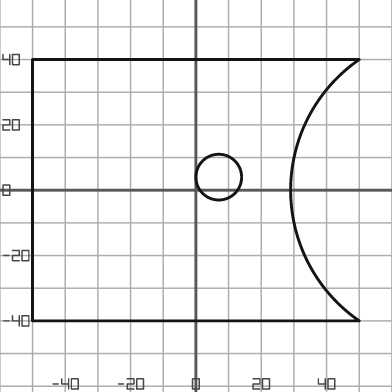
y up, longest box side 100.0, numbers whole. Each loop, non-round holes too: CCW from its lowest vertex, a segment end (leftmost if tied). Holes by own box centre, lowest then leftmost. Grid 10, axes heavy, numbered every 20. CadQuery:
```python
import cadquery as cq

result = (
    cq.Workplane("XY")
    .moveTo(-50.0, -40.0)
    .lineTo(50.0, -40.0)
    .threePointArc((29.0, 0.0), (50.0, 40.0))
    .lineTo(-50.0, 40.0)
    .close()
    .moveTo(7.0, 4.0)
    .circle(7.0)
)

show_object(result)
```